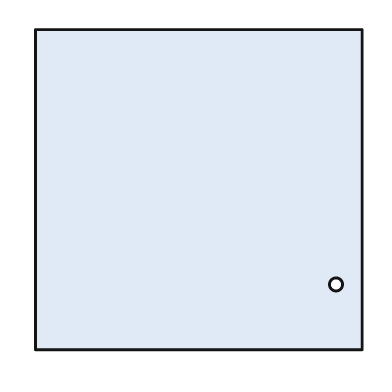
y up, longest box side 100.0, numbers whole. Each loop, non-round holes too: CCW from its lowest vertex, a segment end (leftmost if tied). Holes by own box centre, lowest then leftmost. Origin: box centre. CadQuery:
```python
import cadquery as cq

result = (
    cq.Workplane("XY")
    .moveTo(-50.0, -49.0)
    .lineTo(50.0, -49.0)
    .lineTo(50.0, 49.0)
    .lineTo(-50.0, 49.0)
    .close()
    .moveTo(42.0, -29.0)
    .circle(2.0)
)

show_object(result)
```